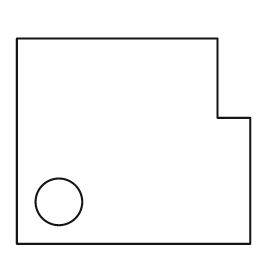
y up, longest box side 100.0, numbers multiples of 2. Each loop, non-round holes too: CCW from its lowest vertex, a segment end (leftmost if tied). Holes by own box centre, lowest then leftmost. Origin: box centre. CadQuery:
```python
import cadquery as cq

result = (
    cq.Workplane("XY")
    .moveTo(-50.0, -44.0)
    .lineTo(50.0, -44.0)
    .lineTo(50.0, 10.0)
    .lineTo(36.0, 10.0)
    .lineTo(36.0, 44.0)
    .lineTo(-50.0, 44.0)
    .close()
    .moveTo(-32.0, -26.0)
    .circle(10.0)
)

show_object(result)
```